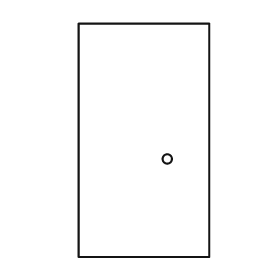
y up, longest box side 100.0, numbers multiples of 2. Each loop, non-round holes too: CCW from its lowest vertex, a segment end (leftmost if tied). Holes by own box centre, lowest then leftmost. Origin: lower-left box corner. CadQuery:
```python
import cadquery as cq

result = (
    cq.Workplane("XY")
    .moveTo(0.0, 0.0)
    .lineTo(56.0, 0.0)
    .lineTo(56.0, 100.0)
    .lineTo(0.0, 100.0)
    .close()
    .moveTo(38.0, 42.0)
    .circle(2.0)
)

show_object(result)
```